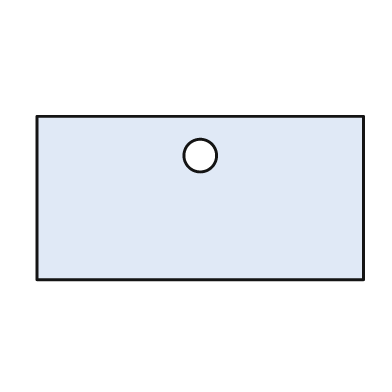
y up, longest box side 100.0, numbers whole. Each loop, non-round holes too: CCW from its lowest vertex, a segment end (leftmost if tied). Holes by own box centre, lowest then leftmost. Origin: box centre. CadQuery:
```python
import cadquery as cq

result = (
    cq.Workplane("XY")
    .moveTo(-50.0, -25.0)
    .lineTo(50.0, -25.0)
    .lineTo(50.0, 25.0)
    .lineTo(-50.0, 25.0)
    .close()
    .moveTo(0.0, 13.0)
    .circle(5.0)
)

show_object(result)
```